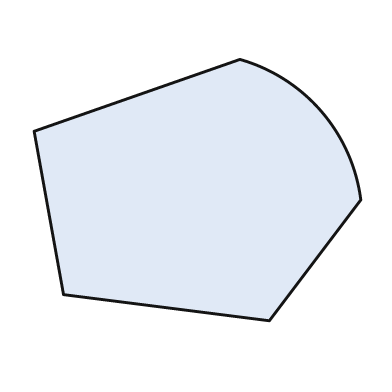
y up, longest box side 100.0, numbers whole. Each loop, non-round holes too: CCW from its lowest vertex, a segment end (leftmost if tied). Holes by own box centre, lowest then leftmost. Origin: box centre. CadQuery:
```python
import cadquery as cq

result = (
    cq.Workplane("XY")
    .moveTo(22.0, -40.0)
    .lineTo(50.0, -3.0)
    .threePointArc((38.0, 24.0), (13.0, 40.0))
    .lineTo(-50.0, 18.0)
    .lineTo(-41.0, -32.0)
    .close()
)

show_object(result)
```